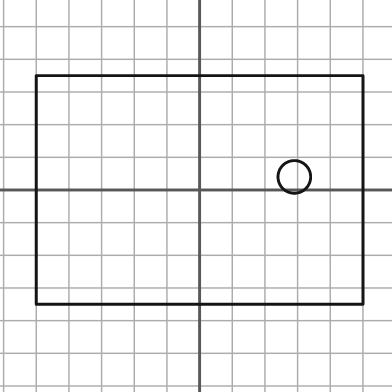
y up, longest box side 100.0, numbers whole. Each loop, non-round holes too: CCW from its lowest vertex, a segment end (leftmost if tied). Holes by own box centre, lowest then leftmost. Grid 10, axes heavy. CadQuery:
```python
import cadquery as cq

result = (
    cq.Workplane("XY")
    .moveTo(-50.0, -35.0)
    .lineTo(50.0, -35.0)
    .lineTo(50.0, 35.0)
    .lineTo(-50.0, 35.0)
    .close()
    .moveTo(29.0, 4.0)
    .circle(5.0)
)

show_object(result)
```